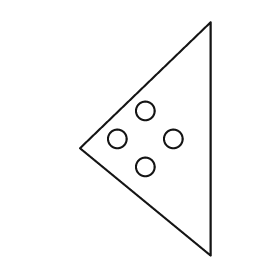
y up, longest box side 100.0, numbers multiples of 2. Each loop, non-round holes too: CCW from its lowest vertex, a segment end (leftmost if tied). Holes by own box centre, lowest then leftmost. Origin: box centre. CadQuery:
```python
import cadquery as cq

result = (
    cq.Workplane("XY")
    .moveTo(28.0, -50.0)
    .lineTo(28.0, 50.0)
    .lineTo(-28.0, -4.0)
    .close()
    .moveTo(0.0, -12.0)
    .circle(4.0)
    .moveTo(-12.0, 0.0)
    .circle(4.0)
    .moveTo(12.0, 0.0)
    .circle(4.0)
    .moveTo(0.0, 12.0)
    .circle(4.0)
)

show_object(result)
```